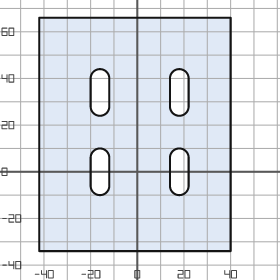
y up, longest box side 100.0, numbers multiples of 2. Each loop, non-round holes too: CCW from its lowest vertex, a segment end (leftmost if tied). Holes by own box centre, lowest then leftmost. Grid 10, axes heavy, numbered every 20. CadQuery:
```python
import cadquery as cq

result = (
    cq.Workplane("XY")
    .moveTo(-42.0, -34.0)
    .lineTo(40.0, -34.0)
    .lineTo(40.0, 66.0)
    .lineTo(-42.0, 66.0)
    .close()
    .moveTo(-20.0, -6.0)
    .threePointArc((-16.0, -10.0), (-12.0, -6.0))
    .lineTo(-12.0, 6.0)
    .threePointArc((-16.0, 10.0), (-20.0, 6.0))
    .close()
    .moveTo(14.0, -6.0)
    .threePointArc((18.0, -10.0), (22.0, -6.0))
    .lineTo(22.0, 6.0)
    .threePointArc((18.0, 10.0), (14.0, 6.0))
    .close()
    .moveTo(-20.0, 28.0)
    .threePointArc((-16.0, 24.0), (-12.0, 28.0))
    .lineTo(-12.0, 40.0)
    .threePointArc((-16.0, 44.0), (-20.0, 40.0))
    .close()
    .moveTo(14.0, 28.0)
    .threePointArc((18.0, 24.0), (22.0, 28.0))
    .lineTo(22.0, 40.0)
    .threePointArc((18.0, 44.0), (14.0, 40.0))
    .close()
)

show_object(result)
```